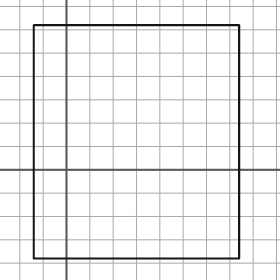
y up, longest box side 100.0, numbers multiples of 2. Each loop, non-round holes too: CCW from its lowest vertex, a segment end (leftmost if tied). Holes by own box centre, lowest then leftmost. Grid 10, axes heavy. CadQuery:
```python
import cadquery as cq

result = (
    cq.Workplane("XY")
    .moveTo(-14.0, -38.0)
    .lineTo(74.0, -38.0)
    .lineTo(74.0, 62.0)
    .lineTo(-14.0, 62.0)
    .close()
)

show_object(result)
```